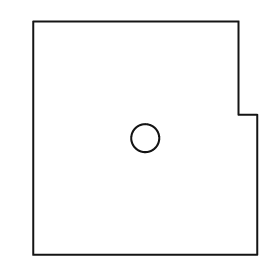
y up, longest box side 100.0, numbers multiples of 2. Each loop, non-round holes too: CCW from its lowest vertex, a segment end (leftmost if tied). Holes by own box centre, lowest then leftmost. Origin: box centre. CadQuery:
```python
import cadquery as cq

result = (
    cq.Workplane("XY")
    .moveTo(-48.0, -50.0)
    .lineTo(48.0, -50.0)
    .lineTo(48.0, 10.0)
    .lineTo(40.0, 10.0)
    .lineTo(40.0, 50.0)
    .lineTo(-48.0, 50.0)
    .close()
    .moveTo(0.0, 0.0)
    .circle(6.0)
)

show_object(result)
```